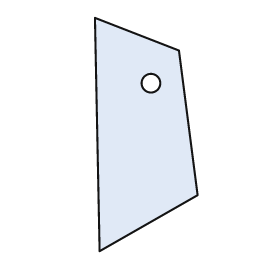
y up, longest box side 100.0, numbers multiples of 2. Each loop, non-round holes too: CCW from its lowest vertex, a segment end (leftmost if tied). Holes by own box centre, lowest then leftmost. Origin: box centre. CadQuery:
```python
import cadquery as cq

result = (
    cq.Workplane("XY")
    .moveTo(-20.0, -50.0)
    .lineTo(22.0, -26.0)
    .lineTo(14.0, 36.0)
    .lineTo(-22.0, 50.0)
    .close()
    .moveTo(2.0, 22.0)
    .circle(4.0)
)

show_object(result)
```